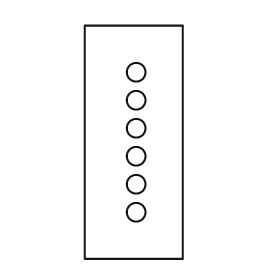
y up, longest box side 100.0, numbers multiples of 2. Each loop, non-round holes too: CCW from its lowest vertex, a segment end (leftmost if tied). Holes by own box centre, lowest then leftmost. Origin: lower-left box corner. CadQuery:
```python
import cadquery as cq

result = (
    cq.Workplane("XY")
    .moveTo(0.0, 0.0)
    .lineTo(42.0, 0.0)
    .lineTo(42.0, 100.0)
    .lineTo(0.0, 100.0)
    .close()
    .moveTo(22.0, 20.0)
    .circle(4.0)
    .moveTo(22.0, 32.0)
    .circle(4.0)
    .moveTo(22.0, 44.0)
    .circle(4.0)
    .moveTo(22.0, 56.0)
    .circle(4.0)
    .moveTo(22.0, 68.0)
    .circle(4.0)
    .moveTo(22.0, 80.0)
    .circle(4.0)
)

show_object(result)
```